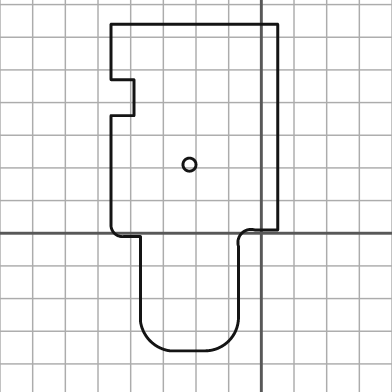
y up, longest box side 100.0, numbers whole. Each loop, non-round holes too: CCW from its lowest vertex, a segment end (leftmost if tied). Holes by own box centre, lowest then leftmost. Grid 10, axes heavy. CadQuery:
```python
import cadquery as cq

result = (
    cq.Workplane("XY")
    .moveTo(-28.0, -36.0)
    .lineTo(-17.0, -36.0)
    .threePointArc((-10.0, -33.0), (-7.0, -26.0))
    .lineTo(-7.0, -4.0)
    .threePointArc((-6.0, 0.0), (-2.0, 1.0))
    .lineTo(5.0, 1.0)
    .lineTo(5.0, 64.0)
    .lineTo(-46.0, 64.0)
    .lineTo(-46.0, 47.0)
    .lineTo(-39.0, 47.0)
    .lineTo(-39.0, 36.0)
    .lineTo(-46.0, 36.0)
    .lineTo(-46.0, 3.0)
    .threePointArc((-45.0, 0.0), (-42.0, -1.0))
    .lineTo(-37.0, -1.0)
    .lineTo(-37.0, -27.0)
    .threePointArc((-34.0, -33.0), (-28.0, -36.0))
    .close()
    .moveTo(-22.0, 21.0)
    .circle(2.0)
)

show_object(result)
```